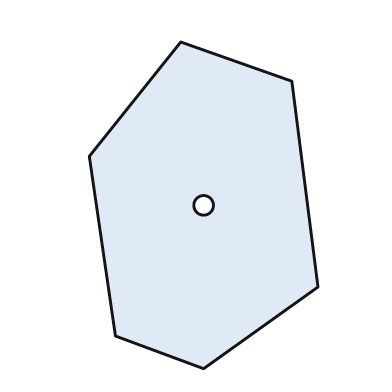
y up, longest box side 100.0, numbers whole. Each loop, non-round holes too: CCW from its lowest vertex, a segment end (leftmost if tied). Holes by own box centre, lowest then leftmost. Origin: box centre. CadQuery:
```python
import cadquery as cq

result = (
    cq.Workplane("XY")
    .moveTo(0.0, -50.0)
    .lineTo(35.0, -25.0)
    .lineTo(27.0, 38.0)
    .lineTo(-7.0, 50.0)
    .lineTo(-35.0, 15.0)
    .lineTo(-27.0, -40.0)
    .close()
    .moveTo(0.0, 0.0)
    .circle(3.0)
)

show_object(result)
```